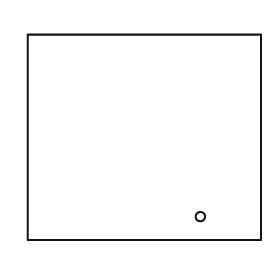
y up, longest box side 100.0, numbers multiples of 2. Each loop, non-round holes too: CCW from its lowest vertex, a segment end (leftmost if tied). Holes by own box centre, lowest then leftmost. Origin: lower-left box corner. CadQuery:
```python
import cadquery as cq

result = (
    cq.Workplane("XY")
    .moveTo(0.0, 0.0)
    .lineTo(100.0, 0.0)
    .lineTo(100.0, 88.0)
    .lineTo(0.0, 88.0)
    .close()
    .moveTo(74.0, 10.0)
    .circle(2.0)
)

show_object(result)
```